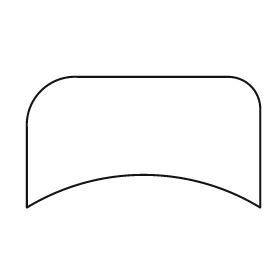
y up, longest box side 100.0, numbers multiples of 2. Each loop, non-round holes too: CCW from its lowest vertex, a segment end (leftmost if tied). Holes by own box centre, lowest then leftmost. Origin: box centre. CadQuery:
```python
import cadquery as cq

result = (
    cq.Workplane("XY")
    .moveTo(-50.0, -28.0)
    .threePointArc((0.0, -14.0), (50.0, -28.0))
    .lineTo(50.0, 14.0)
    .threePointArc((46.0, 24.0), (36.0, 28.0))
    .lineTo(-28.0, 28.0)
    .threePointArc((-44.0, 22.0), (-50.0, 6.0))
    .close()
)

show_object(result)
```